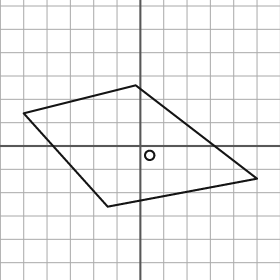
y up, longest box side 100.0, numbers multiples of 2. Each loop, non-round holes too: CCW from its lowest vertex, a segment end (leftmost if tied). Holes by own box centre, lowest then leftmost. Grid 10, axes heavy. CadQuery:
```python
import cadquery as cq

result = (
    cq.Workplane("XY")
    .moveTo(-14.0, -26.0)
    .lineTo(50.0, -14.0)
    .lineTo(-2.0, 26.0)
    .lineTo(-50.0, 14.0)
    .close()
    .moveTo(4.0, -4.0)
    .circle(2.0)
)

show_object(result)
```